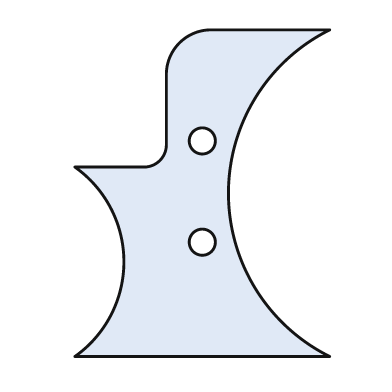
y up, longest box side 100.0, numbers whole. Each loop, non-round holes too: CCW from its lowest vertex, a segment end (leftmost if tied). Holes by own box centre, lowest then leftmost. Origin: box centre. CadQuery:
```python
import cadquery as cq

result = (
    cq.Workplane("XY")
    .moveTo(-39.0, -50.0)
    .lineTo(39.0, -50.0)
    .threePointArc((8.0, 0.0), (39.0, 50.0))
    .lineTo(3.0, 50.0)
    .threePointArc((-7.0, 46.0), (-11.0, 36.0))
    .lineTo(-11.0, 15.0)
    .threePointArc((-13.0, 10.0), (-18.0, 8.0))
    .lineTo(-39.0, 8.0)
    .threePointArc((-24.0, -21.0), (-39.0, -50.0))
    .close()
    .moveTo(0.0, -15.0)
    .circle(4.0)
    .moveTo(0.0, 16.0)
    .circle(4.0)
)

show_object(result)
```